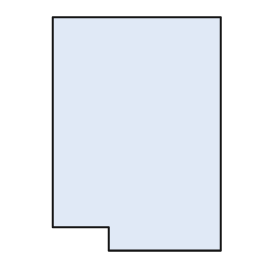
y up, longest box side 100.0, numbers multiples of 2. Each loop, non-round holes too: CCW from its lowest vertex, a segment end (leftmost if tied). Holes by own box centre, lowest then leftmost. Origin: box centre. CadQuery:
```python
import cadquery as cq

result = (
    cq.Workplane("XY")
    .moveTo(-12.0, -50.0)
    .lineTo(36.0, -50.0)
    .lineTo(36.0, 50.0)
    .lineTo(-36.0, 50.0)
    .lineTo(-36.0, -40.0)
    .lineTo(-12.0, -40.0)
    .close()
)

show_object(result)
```